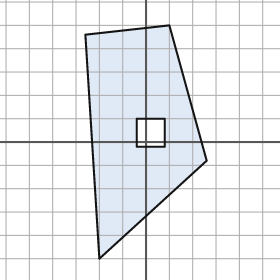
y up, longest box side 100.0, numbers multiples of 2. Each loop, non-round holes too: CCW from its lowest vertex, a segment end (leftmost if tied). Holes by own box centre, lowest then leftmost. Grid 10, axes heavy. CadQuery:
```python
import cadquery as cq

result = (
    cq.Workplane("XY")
    .moveTo(-20.0, -50.0)
    .lineTo(26.0, -8.0)
    .lineTo(10.0, 50.0)
    .lineTo(-26.0, 46.0)
    .close()
    .moveTo(-4.0, -2.0)
    .lineTo(8.0, -2.0)
    .lineTo(8.0, 10.0)
    .lineTo(-4.0, 10.0)
    .close()
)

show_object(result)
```